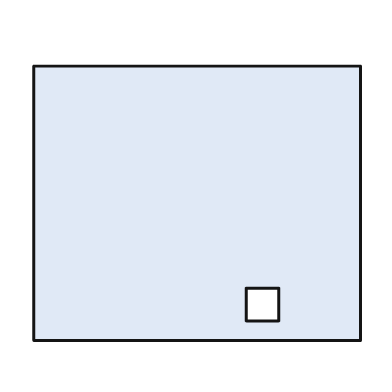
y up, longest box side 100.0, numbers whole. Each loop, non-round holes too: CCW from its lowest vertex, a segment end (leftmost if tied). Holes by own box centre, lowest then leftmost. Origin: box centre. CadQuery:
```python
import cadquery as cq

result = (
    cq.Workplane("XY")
    .moveTo(-50.0, -42.0)
    .lineTo(50.0, -42.0)
    .lineTo(50.0, 42.0)
    .lineTo(-50.0, 42.0)
    .close()
    .moveTo(15.0, -36.0)
    .lineTo(25.0, -36.0)
    .lineTo(25.0, -26.0)
    .lineTo(15.0, -26.0)
    .close()
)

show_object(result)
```